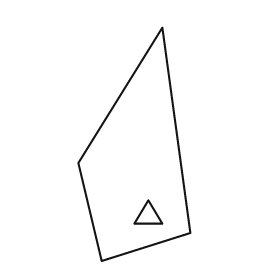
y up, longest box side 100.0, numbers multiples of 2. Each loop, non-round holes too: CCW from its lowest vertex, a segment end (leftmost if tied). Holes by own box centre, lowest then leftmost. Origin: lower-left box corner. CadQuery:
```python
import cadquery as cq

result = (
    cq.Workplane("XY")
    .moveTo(10.0, 0.0)
    .lineTo(48.0, 12.0)
    .lineTo(36.0, 100.0)
    .lineTo(0.0, 42.0)
    .close()
    .moveTo(24.0, 16.0)
    .lineTo(36.0, 16.0)
    .lineTo(30.0, 26.0)
    .close()
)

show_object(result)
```